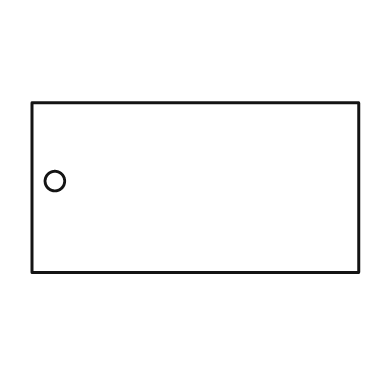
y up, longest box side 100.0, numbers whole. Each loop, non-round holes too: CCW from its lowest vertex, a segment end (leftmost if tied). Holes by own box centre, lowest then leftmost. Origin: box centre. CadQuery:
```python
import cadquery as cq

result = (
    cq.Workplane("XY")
    .moveTo(-50.0, -26.0)
    .lineTo(50.0, -26.0)
    .lineTo(50.0, 26.0)
    .lineTo(-50.0, 26.0)
    .close()
    .moveTo(-43.0, 2.0)
    .circle(3.0)
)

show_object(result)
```